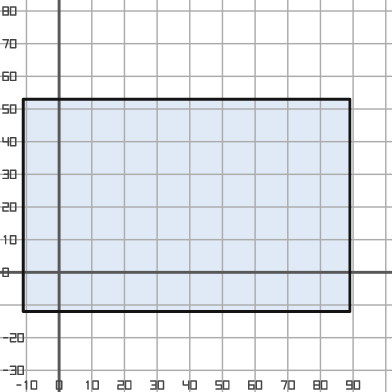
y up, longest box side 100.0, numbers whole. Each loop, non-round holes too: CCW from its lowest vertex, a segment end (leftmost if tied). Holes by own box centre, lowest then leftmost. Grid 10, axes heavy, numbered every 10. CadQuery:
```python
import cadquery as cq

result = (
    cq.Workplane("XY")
    .moveTo(-11.0, -12.0)
    .lineTo(89.0, -12.0)
    .lineTo(89.0, 53.0)
    .lineTo(-11.0, 53.0)
    .close()
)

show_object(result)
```